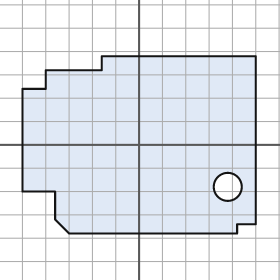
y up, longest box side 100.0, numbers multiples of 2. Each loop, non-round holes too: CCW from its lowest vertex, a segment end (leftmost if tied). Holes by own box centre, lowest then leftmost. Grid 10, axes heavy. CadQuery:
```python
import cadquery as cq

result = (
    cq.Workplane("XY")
    .moveTo(-30.0, -38.0)
    .lineTo(42.0, -38.0)
    .lineTo(42.0, -34.0)
    .lineTo(50.0, -34.0)
    .lineTo(50.0, 38.0)
    .lineTo(-16.0, 38.0)
    .lineTo(-16.0, 32.0)
    .lineTo(-40.0, 32.0)
    .lineTo(-40.0, 24.0)
    .lineTo(-50.0, 24.0)
    .lineTo(-50.0, -20.0)
    .lineTo(-36.0, -20.0)
    .lineTo(-36.0, -32.0)
    .close()
    .moveTo(38.0, -18.0)
    .circle(6.0)
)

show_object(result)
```